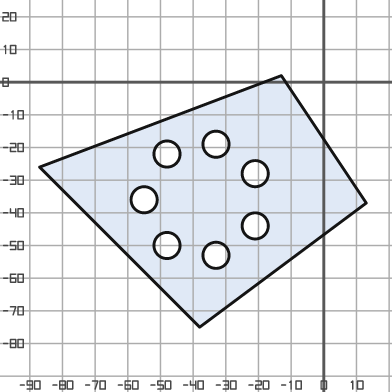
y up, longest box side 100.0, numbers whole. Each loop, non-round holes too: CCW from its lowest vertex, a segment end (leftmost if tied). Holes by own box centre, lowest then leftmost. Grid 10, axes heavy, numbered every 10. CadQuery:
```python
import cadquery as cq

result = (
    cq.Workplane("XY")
    .moveTo(-38.0, -75.0)
    .lineTo(13.0, -37.0)
    .lineTo(-13.0, 2.0)
    .lineTo(-87.0, -26.0)
    .close()
    .moveTo(-33.0, -53.0)
    .circle(4.0)
    .moveTo(-48.0, -50.0)
    .circle(4.0)
    .moveTo(-21.0, -44.0)
    .circle(4.0)
    .moveTo(-55.0, -36.0)
    .circle(4.0)
    .moveTo(-21.0, -28.0)
    .circle(4.0)
    .moveTo(-48.0, -22.0)
    .circle(4.0)
    .moveTo(-33.0, -19.0)
    .circle(4.0)
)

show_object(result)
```